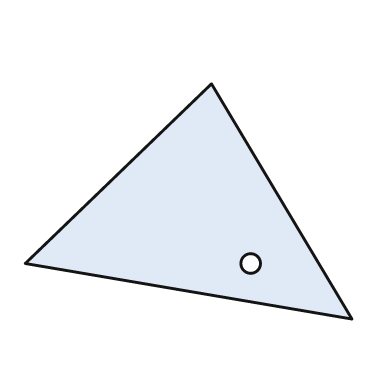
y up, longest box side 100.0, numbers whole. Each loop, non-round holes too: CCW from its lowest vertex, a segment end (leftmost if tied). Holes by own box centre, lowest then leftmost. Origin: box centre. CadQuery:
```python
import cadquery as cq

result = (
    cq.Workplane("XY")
    .moveTo(50.0, -36.0)
    .lineTo(7.0, 36.0)
    .lineTo(-50.0, -19.0)
    .close()
    .moveTo(19.0, -19.0)
    .circle(3.0)
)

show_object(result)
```